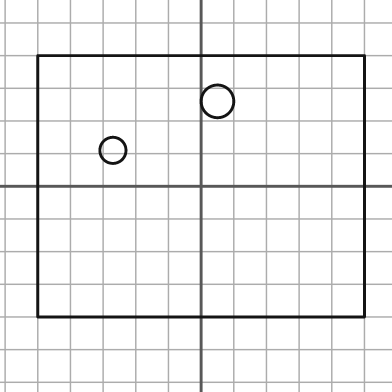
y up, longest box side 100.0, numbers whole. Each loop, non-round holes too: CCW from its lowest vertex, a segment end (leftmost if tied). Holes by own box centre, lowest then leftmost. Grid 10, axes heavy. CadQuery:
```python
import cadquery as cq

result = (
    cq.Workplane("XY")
    .moveTo(-50.0, -40.0)
    .lineTo(50.0, -40.0)
    .lineTo(50.0, 40.0)
    .lineTo(-50.0, 40.0)
    .close()
    .moveTo(-27.0, 11.0)
    .circle(4.0)
    .moveTo(5.0, 26.0)
    .circle(5.0)
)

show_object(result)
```